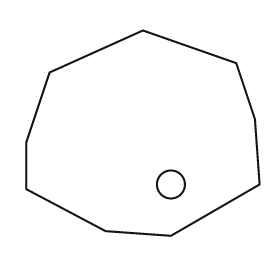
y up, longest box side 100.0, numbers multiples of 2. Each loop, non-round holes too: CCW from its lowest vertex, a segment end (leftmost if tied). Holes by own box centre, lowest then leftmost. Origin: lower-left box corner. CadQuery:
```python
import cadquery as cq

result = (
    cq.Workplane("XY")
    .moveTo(62.0, 0.0)
    .lineTo(100.0, 22.0)
    .lineTo(98.0, 50.0)
    .lineTo(90.0, 74.0)
    .lineTo(50.0, 88.0)
    .lineTo(10.0, 70.0)
    .lineTo(0.0, 40.0)
    .lineTo(0.0, 20.0)
    .lineTo(34.0, 2.0)
    .close()
    .moveTo(62.0, 22.0)
    .circle(6.0)
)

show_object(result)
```